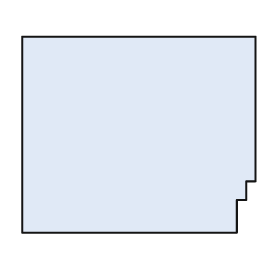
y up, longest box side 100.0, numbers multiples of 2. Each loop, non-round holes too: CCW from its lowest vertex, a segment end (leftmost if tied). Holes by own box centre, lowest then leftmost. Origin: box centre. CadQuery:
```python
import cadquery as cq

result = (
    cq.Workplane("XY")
    .moveTo(-50.0, -42.0)
    .lineTo(42.0, -42.0)
    .lineTo(42.0, -28.0)
    .lineTo(46.0, -28.0)
    .lineTo(46.0, -20.0)
    .lineTo(50.0, -20.0)
    .lineTo(50.0, 42.0)
    .lineTo(-50.0, 42.0)
    .close()
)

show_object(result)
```